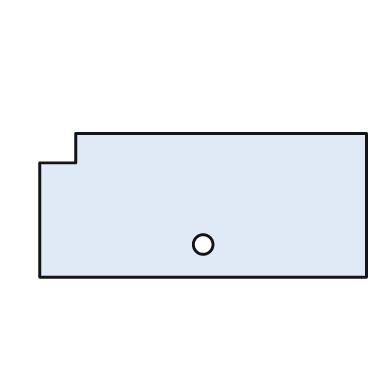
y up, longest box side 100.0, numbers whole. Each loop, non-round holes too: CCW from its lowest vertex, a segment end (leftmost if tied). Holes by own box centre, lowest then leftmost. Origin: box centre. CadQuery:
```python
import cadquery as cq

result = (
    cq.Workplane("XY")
    .moveTo(-50.0, -22.0)
    .lineTo(50.0, -22.0)
    .lineTo(50.0, 22.0)
    .lineTo(-39.0, 22.0)
    .lineTo(-39.0, 13.0)
    .lineTo(-50.0, 13.0)
    .close()
    .moveTo(0.0, -12.0)
    .circle(3.0)
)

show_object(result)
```